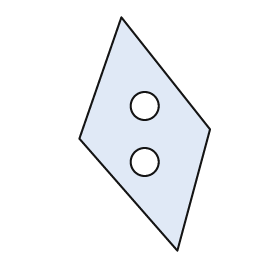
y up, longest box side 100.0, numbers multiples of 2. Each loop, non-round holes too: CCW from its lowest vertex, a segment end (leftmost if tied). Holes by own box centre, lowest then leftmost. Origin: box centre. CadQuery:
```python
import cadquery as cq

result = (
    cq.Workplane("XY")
    .moveTo(14.0, -50.0)
    .lineTo(28.0, 2.0)
    .lineTo(-10.0, 50.0)
    .lineTo(-28.0, -2.0)
    .close()
    .moveTo(0.0, -12.0)
    .circle(6.0)
    .moveTo(0.0, 12.0)
    .circle(6.0)
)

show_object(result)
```